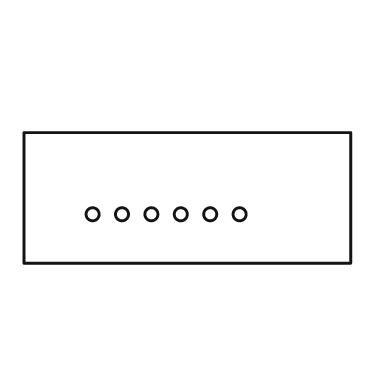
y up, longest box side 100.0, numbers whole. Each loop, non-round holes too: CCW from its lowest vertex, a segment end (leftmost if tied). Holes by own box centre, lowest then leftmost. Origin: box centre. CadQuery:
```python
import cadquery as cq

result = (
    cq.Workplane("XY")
    .moveTo(-50.0, -20.0)
    .lineTo(50.0, -20.0)
    .lineTo(50.0, 20.0)
    .lineTo(-50.0, 20.0)
    .close()
    .moveTo(-29.0, -5.0)
    .circle(2.0)
    .moveTo(-20.0, -5.0)
    .circle(2.0)
    .moveTo(-11.0, -5.0)
    .circle(2.0)
    .moveTo(-2.0, -5.0)
    .circle(2.0)
    .moveTo(7.0, -5.0)
    .circle(2.0)
    .moveTo(16.0, -5.0)
    .circle(2.0)
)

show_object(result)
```